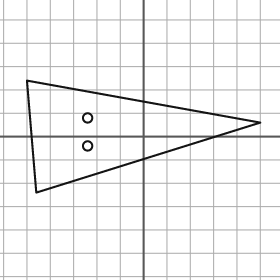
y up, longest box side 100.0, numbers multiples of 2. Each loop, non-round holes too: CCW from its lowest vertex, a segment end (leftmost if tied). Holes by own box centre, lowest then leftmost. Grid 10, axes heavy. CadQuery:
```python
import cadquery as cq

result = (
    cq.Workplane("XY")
    .moveTo(-46.0, -24.0)
    .lineTo(50.0, 6.0)
    .lineTo(-50.0, 24.0)
    .close()
    .moveTo(-24.0, -4.0)
    .circle(2.0)
    .moveTo(-24.0, 8.0)
    .circle(2.0)
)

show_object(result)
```